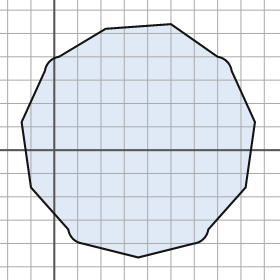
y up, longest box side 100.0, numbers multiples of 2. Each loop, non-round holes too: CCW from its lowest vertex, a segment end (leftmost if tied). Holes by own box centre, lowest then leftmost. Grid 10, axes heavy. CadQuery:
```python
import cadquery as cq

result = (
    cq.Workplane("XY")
    .moveTo(36.0, -46.0)
    .lineTo(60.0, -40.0)
    .threePointArc((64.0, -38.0), (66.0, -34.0))
    .lineTo(82.0, -16.0)
    .lineTo(86.0, 12.0)
    .lineTo(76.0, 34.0)
    .threePointArc((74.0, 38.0), (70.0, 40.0))
    .lineTo(50.0, 54.0)
    .lineTo(22.0, 52.0)
    .lineTo(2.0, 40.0)
    .threePointArc((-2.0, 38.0), (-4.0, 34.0))
    .lineTo(-14.0, 12.0)
    .lineTo(-10.0, -16.0)
    .lineTo(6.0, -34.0)
    .threePointArc((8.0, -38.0), (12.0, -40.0))
    .close()
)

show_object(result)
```